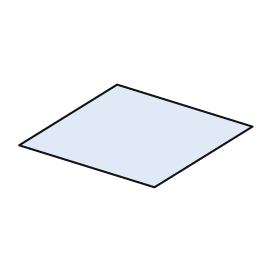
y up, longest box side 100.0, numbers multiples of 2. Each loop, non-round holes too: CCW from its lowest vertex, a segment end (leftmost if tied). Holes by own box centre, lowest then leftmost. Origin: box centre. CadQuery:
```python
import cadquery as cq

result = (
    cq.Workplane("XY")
    .moveTo(8.0, -22.0)
    .lineTo(50.0, 4.0)
    .lineTo(-8.0, 22.0)
    .lineTo(-50.0, -4.0)
    .close()
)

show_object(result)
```